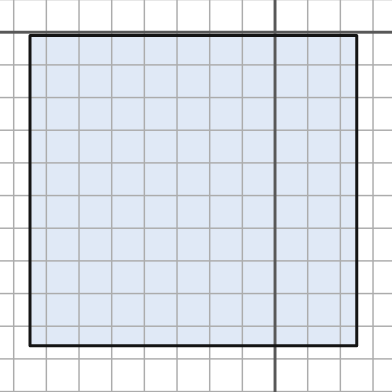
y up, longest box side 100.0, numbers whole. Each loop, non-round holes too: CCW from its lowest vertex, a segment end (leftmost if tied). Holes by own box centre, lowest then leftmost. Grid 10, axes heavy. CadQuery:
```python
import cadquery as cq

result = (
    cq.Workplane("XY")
    .moveTo(-75.0, -96.0)
    .lineTo(25.0, -96.0)
    .lineTo(25.0, -1.0)
    .lineTo(-75.0, -1.0)
    .close()
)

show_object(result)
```